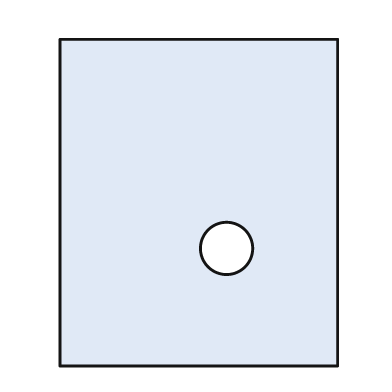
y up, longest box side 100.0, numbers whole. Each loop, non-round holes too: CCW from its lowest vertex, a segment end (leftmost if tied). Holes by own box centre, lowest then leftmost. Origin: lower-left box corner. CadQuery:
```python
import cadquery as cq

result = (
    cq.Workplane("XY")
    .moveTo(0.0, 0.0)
    .lineTo(85.0, 0.0)
    .lineTo(85.0, 100.0)
    .lineTo(0.0, 100.0)
    .close()
    .moveTo(51.0, 36.0)
    .circle(8.0)
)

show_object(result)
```